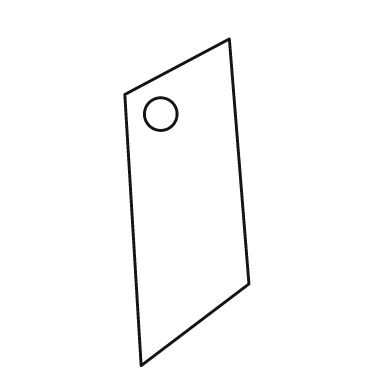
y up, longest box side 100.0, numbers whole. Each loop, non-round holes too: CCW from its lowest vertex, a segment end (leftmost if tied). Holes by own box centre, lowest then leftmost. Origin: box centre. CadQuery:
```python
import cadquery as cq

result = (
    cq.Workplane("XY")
    .moveTo(-14.0, -50.0)
    .lineTo(19.0, -25.0)
    .lineTo(13.0, 50.0)
    .lineTo(-19.0, 33.0)
    .close()
    .moveTo(-8.0, 27.0)
    .circle(5.0)
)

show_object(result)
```